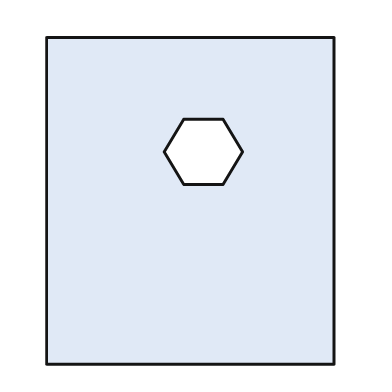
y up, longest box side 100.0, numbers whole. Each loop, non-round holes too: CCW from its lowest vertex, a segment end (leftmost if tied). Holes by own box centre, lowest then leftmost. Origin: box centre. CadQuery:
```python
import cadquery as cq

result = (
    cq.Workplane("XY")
    .moveTo(-44.0, -50.0)
    .lineTo(44.0, -50.0)
    .lineTo(44.0, 50.0)
    .lineTo(-44.0, 50.0)
    .close()
    .moveTo(-2.0, 5.0)
    .lineTo(10.0, 5.0)
    .lineTo(16.0, 15.0)
    .lineTo(10.0, 25.0)
    .lineTo(-2.0, 25.0)
    .lineTo(-8.0, 15.0)
    .close()
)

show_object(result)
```